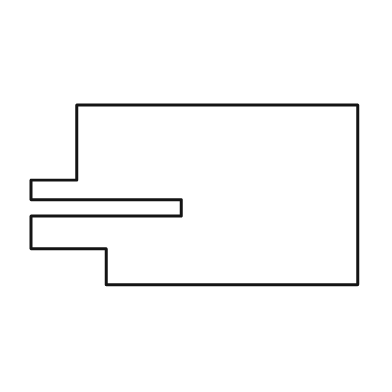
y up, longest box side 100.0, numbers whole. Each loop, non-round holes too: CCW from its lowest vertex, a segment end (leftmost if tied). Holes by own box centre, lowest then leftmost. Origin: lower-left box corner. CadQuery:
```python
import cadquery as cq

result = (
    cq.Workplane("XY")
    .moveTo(23.0, 0.0)
    .lineTo(100.0, 0.0)
    .lineTo(100.0, 55.0)
    .lineTo(14.0, 55.0)
    .lineTo(14.0, 32.0)
    .lineTo(0.0, 32.0)
    .lineTo(0.0, 26.0)
    .lineTo(46.0, 26.0)
    .lineTo(46.0, 21.0)
    .lineTo(0.0, 21.0)
    .lineTo(0.0, 11.0)
    .lineTo(23.0, 11.0)
    .close()
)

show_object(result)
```